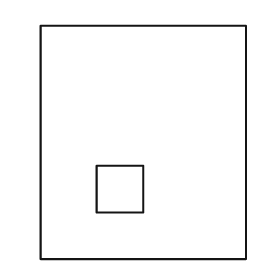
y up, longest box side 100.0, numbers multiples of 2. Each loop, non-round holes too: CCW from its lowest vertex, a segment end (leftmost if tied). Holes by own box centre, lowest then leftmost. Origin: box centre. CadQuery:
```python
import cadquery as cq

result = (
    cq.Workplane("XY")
    .moveTo(-44.0, -50.0)
    .lineTo(44.0, -50.0)
    .lineTo(44.0, 50.0)
    .lineTo(-44.0, 50.0)
    .close()
    .moveTo(-20.0, -30.0)
    .lineTo(0.0, -30.0)
    .lineTo(0.0, -10.0)
    .lineTo(-20.0, -10.0)
    .close()
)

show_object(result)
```